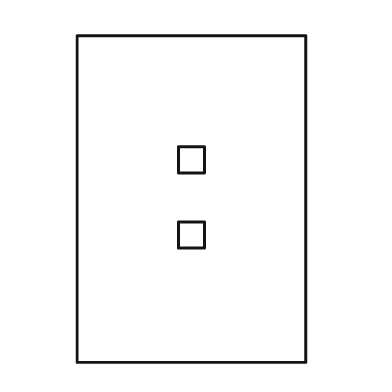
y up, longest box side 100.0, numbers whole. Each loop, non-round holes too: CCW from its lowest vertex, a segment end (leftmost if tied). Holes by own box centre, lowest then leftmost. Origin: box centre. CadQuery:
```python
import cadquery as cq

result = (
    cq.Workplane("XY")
    .moveTo(-35.0, -50.0)
    .lineTo(35.0, -50.0)
    .lineTo(35.0, 50.0)
    .lineTo(-35.0, 50.0)
    .close()
    .moveTo(-4.0, -15.0)
    .lineTo(4.0, -15.0)
    .lineTo(4.0, -7.0)
    .lineTo(-4.0, -7.0)
    .close()
    .moveTo(-4.0, 8.0)
    .lineTo(4.0, 8.0)
    .lineTo(4.0, 16.0)
    .lineTo(-4.0, 16.0)
    .close()
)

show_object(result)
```